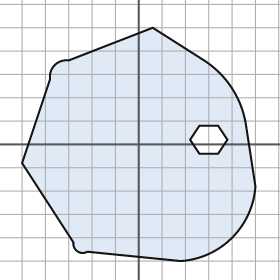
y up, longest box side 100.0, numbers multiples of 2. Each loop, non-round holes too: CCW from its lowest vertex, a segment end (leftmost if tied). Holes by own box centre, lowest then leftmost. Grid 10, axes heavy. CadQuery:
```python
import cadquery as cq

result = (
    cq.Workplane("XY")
    .moveTo(18.0, -50.0)
    .threePointArc((40.0, -40.0), (50.0, -18.0))
    .lineTo(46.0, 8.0)
    .threePointArc((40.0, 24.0), (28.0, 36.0))
    .lineTo(6.0, 50.0)
    .lineTo(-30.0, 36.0)
    .threePointArc((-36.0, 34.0), (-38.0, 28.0))
    .lineTo(-50.0, -8.0)
    .lineTo(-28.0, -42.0)
    .threePointArc((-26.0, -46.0), (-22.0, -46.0))
    .close()
    .moveTo(26.0, -4.0)
    .lineTo(34.0, -4.0)
    .lineTo(38.0, 2.0)
    .lineTo(34.0, 8.0)
    .lineTo(26.0, 8.0)
    .lineTo(22.0, 2.0)
    .close()
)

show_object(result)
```